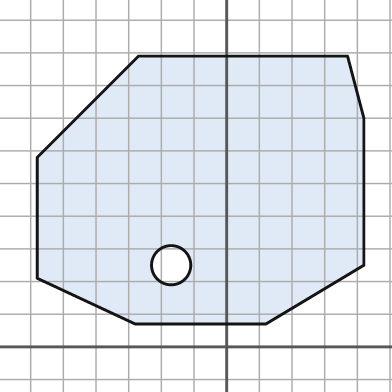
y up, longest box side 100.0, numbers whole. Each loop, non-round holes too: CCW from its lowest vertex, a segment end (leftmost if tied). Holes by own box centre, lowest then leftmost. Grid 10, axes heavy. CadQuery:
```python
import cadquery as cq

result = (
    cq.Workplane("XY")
    .moveTo(-28.0, 7.0)
    .lineTo(12.0, 7.0)
    .lineTo(42.0, 25.0)
    .lineTo(42.0, 70.0)
    .lineTo(37.0, 89.0)
    .lineTo(-27.0, 89.0)
    .lineTo(-58.0, 58.0)
    .lineTo(-58.0, 21.0)
    .close()
    .moveTo(-17.0, 25.0)
    .circle(6.0)
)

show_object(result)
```